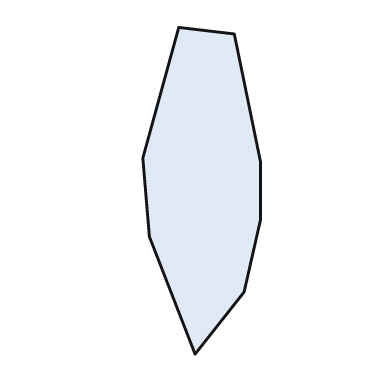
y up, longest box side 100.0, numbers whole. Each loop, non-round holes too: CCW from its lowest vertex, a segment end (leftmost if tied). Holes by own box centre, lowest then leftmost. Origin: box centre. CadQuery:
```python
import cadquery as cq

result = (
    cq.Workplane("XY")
    .moveTo(-2.0, -50.0)
    .lineTo(13.0, -31.0)
    .lineTo(18.0, -9.0)
    .lineTo(18.0, 9.0)
    .lineTo(10.0, 48.0)
    .lineTo(-7.0, 50.0)
    .lineTo(-18.0, 10.0)
    .lineTo(-16.0, -14.0)
    .close()
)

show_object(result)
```